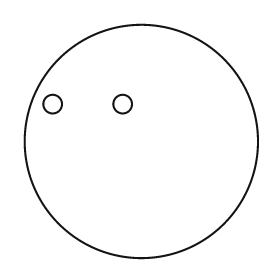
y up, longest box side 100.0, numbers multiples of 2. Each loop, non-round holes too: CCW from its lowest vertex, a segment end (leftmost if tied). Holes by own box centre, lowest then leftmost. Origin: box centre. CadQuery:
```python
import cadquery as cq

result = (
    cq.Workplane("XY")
    .moveTo(0.0, 0.0)
    .circle(50.0)
    .moveTo(-38.0, 16.0)
    .circle(4.0)
    .moveTo(-8.0, 16.0)
    .circle(4.0)
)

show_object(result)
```